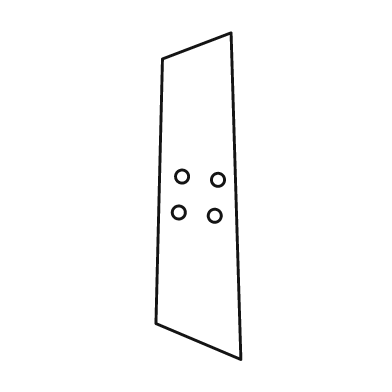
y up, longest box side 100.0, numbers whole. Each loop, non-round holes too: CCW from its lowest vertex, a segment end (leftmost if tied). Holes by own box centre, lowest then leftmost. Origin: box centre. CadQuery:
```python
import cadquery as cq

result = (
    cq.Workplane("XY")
    .moveTo(13.0, -50.0)
    .lineTo(10.0, 50.0)
    .lineTo(-11.0, 42.0)
    .lineTo(-13.0, -39.0)
    .close()
    .moveTo(5.0, -6.0)
    .circle(2.0)
    .moveTo(-6.0, -5.0)
    .circle(2.0)
    .moveTo(6.0, 5.0)
    .circle(2.0)
    .moveTo(-5.0, 6.0)
    .circle(2.0)
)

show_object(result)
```